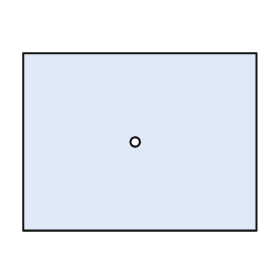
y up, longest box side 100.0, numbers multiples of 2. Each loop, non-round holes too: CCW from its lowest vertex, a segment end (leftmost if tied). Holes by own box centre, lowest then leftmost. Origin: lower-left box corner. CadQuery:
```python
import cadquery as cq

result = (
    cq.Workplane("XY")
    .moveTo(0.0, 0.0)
    .lineTo(100.0, 0.0)
    .lineTo(100.0, 76.0)
    .lineTo(0.0, 76.0)
    .close()
    .moveTo(48.0, 38.0)
    .circle(2.0)
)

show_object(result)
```